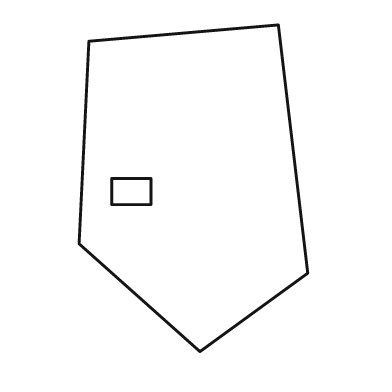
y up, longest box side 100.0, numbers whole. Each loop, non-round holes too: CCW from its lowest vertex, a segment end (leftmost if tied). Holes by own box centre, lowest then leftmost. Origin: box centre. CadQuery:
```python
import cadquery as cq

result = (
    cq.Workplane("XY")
    .moveTo(2.0, -50.0)
    .lineTo(35.0, -26.0)
    .lineTo(26.0, 50.0)
    .lineTo(-32.0, 45.0)
    .lineTo(-35.0, -17.0)
    .close()
    .moveTo(-25.0, -5.0)
    .lineTo(-13.0, -5.0)
    .lineTo(-13.0, 3.0)
    .lineTo(-25.0, 3.0)
    .close()
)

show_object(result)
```